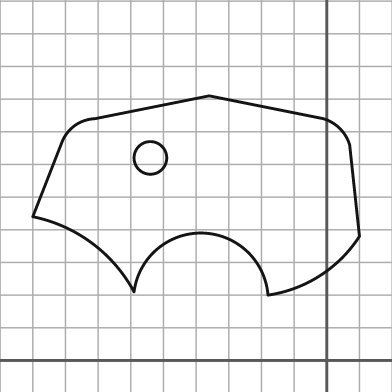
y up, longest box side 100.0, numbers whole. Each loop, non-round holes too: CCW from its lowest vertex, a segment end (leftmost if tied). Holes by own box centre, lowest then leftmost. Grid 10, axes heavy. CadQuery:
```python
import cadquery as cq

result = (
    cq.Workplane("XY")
    .moveTo(-18.0, 20.0)
    .threePointArc((-2.0, 26.0), (10.0, 38.0))
    .lineTo(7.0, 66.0)
    .threePointArc((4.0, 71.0), (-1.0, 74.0))
    .lineTo(-36.0, 81.0)
    .lineTo(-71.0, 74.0)
    .threePointArc((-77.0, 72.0), (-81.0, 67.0))
    .lineTo(-90.0, 44.0)
    .threePointArc((-72.0, 36.0), (-59.0, 21.0))
    .threePointArc((-38.0, 39.0), (-18.0, 20.0))
    .close()
    .moveTo(-54.0, 62.0)
    .circle(5.0)
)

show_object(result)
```